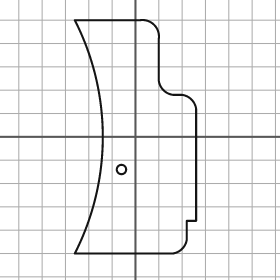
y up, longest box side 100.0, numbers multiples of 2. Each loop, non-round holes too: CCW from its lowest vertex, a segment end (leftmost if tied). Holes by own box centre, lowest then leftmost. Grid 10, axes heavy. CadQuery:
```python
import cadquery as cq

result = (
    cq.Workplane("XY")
    .moveTo(-26.0, -50.0)
    .lineTo(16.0, -50.0)
    .threePointArc((20.0, -48.0), (22.0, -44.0))
    .lineTo(22.0, -36.0)
    .lineTo(26.0, -36.0)
    .lineTo(26.0, 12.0)
    .threePointArc((24.0, 16.0), (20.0, 18.0))
    .lineTo(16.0, 18.0)
    .threePointArc((12.0, 20.0), (10.0, 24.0))
    .lineTo(10.0, 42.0)
    .threePointArc((8.0, 48.0), (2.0, 50.0))
    .lineTo(-26.0, 50.0)
    .threePointArc((-14.0, 0.0), (-26.0, -50.0))
    .close()
    .moveTo(-6.0, -14.0)
    .circle(2.0)
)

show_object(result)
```